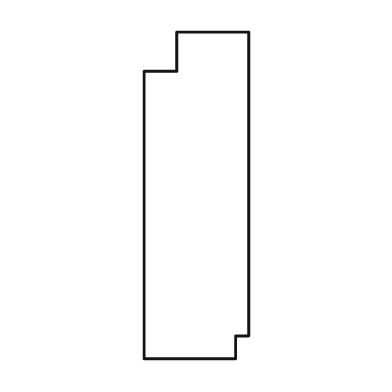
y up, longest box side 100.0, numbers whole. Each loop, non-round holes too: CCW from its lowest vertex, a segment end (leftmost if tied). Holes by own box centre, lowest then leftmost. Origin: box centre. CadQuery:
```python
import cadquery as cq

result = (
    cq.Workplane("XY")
    .moveTo(-16.0, -50.0)
    .lineTo(12.0, -50.0)
    .lineTo(12.0, -43.0)
    .lineTo(16.0, -43.0)
    .lineTo(16.0, 50.0)
    .lineTo(-6.0, 50.0)
    .lineTo(-6.0, 38.0)
    .lineTo(-16.0, 38.0)
    .close()
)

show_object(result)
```